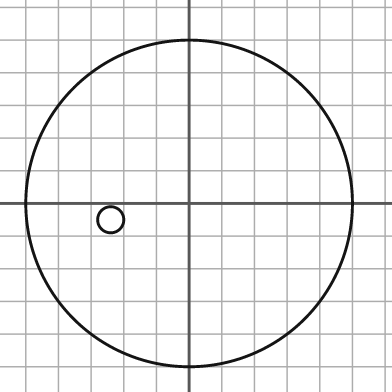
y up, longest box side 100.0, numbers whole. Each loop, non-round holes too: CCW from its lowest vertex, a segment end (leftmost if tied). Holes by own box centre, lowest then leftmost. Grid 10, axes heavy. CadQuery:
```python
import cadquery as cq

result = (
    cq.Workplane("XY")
    .moveTo(0.0, 0.0)
    .circle(50.0)
    .moveTo(-24.0, -5.0)
    .circle(4.0)
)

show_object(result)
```